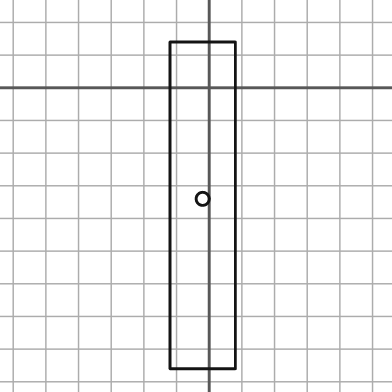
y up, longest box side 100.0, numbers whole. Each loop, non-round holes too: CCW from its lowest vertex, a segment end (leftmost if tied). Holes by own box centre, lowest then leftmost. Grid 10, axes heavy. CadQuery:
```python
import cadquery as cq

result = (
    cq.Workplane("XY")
    .moveTo(-12.0, -86.0)
    .lineTo(8.0, -86.0)
    .lineTo(8.0, 14.0)
    .lineTo(-12.0, 14.0)
    .close()
    .moveTo(-2.0, -34.0)
    .circle(2.0)
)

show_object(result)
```